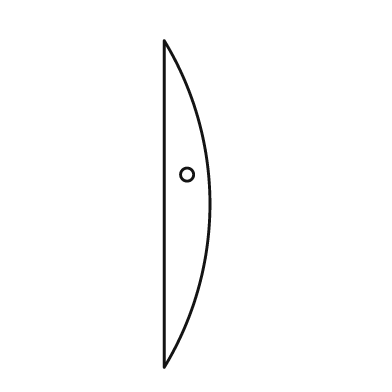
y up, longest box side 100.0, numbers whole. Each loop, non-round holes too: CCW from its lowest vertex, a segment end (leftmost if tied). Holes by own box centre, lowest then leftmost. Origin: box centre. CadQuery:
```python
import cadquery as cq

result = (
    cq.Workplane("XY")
    .moveTo(-7.0, -50.0)
    .threePointArc((7.0, 0.0), (-7.0, 50.0))
    .close()
    .moveTo(0.0, 9.0)
    .circle(2.0)
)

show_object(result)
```